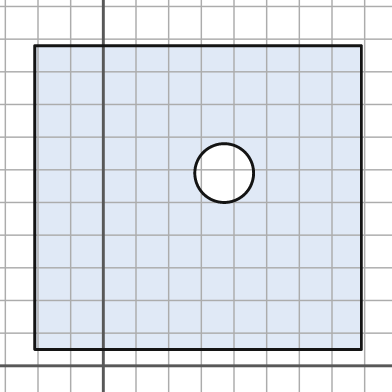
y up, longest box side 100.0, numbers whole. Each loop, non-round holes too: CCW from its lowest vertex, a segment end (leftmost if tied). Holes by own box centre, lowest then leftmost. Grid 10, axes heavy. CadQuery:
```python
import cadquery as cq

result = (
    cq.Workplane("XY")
    .moveTo(-21.0, 5.0)
    .lineTo(79.0, 5.0)
    .lineTo(79.0, 98.0)
    .lineTo(-21.0, 98.0)
    .close()
    .moveTo(37.0, 59.0)
    .circle(9.0)
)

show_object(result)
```